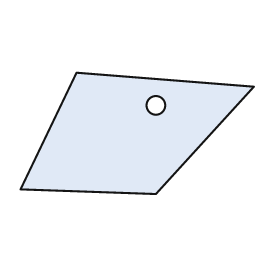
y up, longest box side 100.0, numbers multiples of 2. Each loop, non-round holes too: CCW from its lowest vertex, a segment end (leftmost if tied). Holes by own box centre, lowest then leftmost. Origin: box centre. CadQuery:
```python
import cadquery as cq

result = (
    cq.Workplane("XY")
    .moveTo(8.0, -26.0)
    .lineTo(50.0, 20.0)
    .lineTo(-26.0, 26.0)
    .lineTo(-50.0, -24.0)
    .close()
    .moveTo(8.0, 12.0)
    .circle(4.0)
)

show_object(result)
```